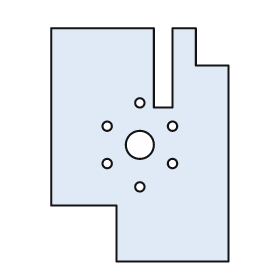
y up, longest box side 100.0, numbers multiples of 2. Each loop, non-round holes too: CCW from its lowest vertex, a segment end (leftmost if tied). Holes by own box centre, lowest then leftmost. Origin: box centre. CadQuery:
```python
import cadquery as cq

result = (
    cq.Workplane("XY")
    .moveTo(-10.0, -50.0)
    .lineTo(38.0, -50.0)
    .lineTo(38.0, 34.0)
    .lineTo(24.0, 34.0)
    .lineTo(24.0, 50.0)
    .lineTo(14.0, 50.0)
    .lineTo(14.0, 16.0)
    .lineTo(6.0, 16.0)
    .lineTo(6.0, 50.0)
    .lineTo(-38.0, 50.0)
    .lineTo(-38.0, -26.0)
    .lineTo(-10.0, -26.0)
    .close()
    .moveTo(0.0, -18.0)
    .circle(2.0)
    .moveTo(-14.0, -8.0)
    .circle(2.0)
    .moveTo(14.0, -8.0)
    .circle(2.0)
    .moveTo(0.0, 0.0)
    .circle(6.0)
    .moveTo(-14.0, 8.0)
    .circle(2.0)
    .moveTo(14.0, 8.0)
    .circle(2.0)
    .moveTo(0.0, 18.0)
    .circle(2.0)
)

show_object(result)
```